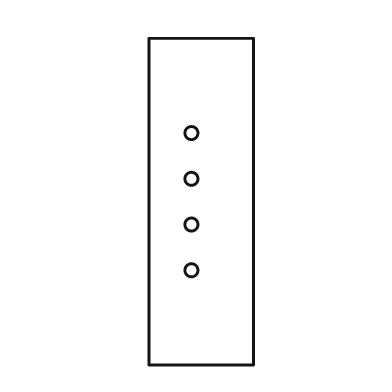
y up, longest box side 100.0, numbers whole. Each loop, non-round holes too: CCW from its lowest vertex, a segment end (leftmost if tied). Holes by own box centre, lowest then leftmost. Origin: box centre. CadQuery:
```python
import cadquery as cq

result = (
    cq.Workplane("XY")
    .moveTo(-16.0, -50.0)
    .lineTo(16.0, -50.0)
    .lineTo(16.0, 50.0)
    .lineTo(-16.0, 50.0)
    .close()
    .moveTo(-3.0, -21.0)
    .circle(2.0)
    .moveTo(-3.0, -7.0)
    .circle(2.0)
    .moveTo(-3.0, 7.0)
    .circle(2.0)
    .moveTo(-3.0, 21.0)
    .circle(2.0)
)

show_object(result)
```